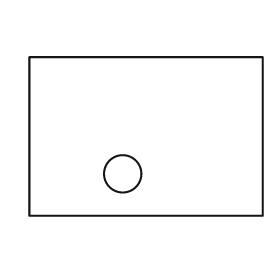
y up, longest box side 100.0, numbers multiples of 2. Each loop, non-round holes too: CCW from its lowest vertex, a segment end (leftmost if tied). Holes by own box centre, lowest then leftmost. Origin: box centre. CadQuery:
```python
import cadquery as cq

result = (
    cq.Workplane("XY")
    .moveTo(-50.0, -34.0)
    .lineTo(50.0, -34.0)
    .lineTo(50.0, 34.0)
    .lineTo(-50.0, 34.0)
    .close()
    .moveTo(-10.0, -16.0)
    .circle(8.0)
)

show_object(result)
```